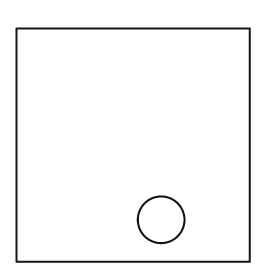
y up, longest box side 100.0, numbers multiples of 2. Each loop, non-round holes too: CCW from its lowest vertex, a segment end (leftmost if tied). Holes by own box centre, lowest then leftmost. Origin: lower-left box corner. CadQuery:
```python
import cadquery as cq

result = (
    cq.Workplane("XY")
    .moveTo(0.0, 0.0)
    .lineTo(100.0, 0.0)
    .lineTo(100.0, 100.0)
    .lineTo(0.0, 100.0)
    .close()
    .moveTo(62.0, 18.0)
    .circle(10.0)
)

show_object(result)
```